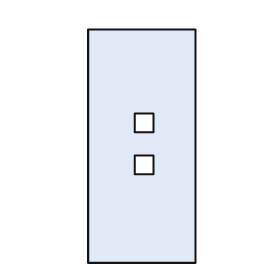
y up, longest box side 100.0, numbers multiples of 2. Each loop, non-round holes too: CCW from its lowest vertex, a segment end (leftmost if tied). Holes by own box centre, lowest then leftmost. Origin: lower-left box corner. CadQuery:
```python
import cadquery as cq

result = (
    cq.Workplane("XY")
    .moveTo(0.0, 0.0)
    .lineTo(46.0, 0.0)
    .lineTo(46.0, 100.0)
    .lineTo(0.0, 100.0)
    .close()
    .moveTo(20.0, 38.0)
    .lineTo(28.0, 38.0)
    .lineTo(28.0, 46.0)
    .lineTo(20.0, 46.0)
    .close()
    .moveTo(20.0, 56.0)
    .lineTo(28.0, 56.0)
    .lineTo(28.0, 64.0)
    .lineTo(20.0, 64.0)
    .close()
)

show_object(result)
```